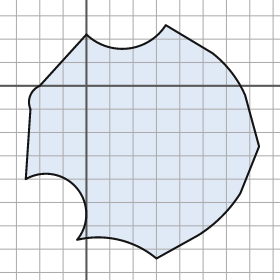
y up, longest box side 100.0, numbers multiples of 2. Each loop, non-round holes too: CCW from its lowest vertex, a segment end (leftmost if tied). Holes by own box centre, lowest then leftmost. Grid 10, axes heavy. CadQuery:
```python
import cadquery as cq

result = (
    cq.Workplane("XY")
    .moveTo(30.0, -74.0)
    .lineTo(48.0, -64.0)
    .threePointArc((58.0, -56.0), (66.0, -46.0))
    .lineTo(74.0, -26.0)
    .lineTo(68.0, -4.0)
    .threePointArc((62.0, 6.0), (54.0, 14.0))
    .lineTo(34.0, 26.0)
    .threePointArc((18.0, 16.0), (0.0, 22.0))
    .lineTo(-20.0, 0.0)
    .threePointArc((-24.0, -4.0), (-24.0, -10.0))
    .lineTo(-26.0, -40.0)
    .threePointArc((-4.0, -44.0), (-4.0, -66.0))
    .threePointArc((14.0, -66.0), (30.0, -74.0))
    .close()
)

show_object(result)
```